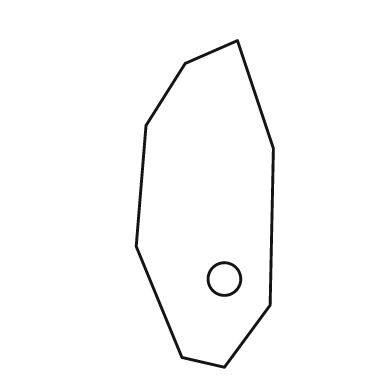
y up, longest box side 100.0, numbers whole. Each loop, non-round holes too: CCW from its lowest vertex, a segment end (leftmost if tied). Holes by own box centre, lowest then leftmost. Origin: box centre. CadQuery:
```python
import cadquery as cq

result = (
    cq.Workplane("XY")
    .moveTo(6.0, -50.0)
    .lineTo(20.0, -31.0)
    .lineTo(21.0, 17.0)
    .lineTo(10.0, 50.0)
    .lineTo(-6.0, 43.0)
    .lineTo(-18.0, 24.0)
    .lineTo(-21.0, -13.0)
    .lineTo(-7.0, -47.0)
    .close()
    .moveTo(6.0, -23.0)
    .circle(5.0)
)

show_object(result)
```